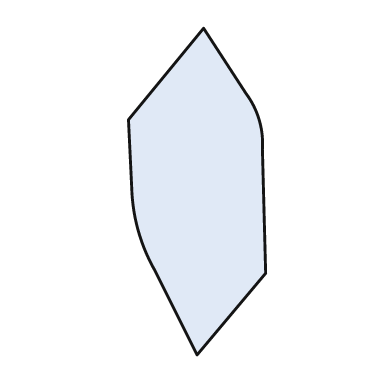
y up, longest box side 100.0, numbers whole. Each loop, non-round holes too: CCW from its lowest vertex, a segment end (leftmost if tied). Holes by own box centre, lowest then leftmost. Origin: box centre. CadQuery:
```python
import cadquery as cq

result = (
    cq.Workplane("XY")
    .moveTo(0.0, -50.0)
    .lineTo(21.0, -25.0)
    .lineTo(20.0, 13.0)
    .threePointArc((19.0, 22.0), (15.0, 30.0))
    .lineTo(2.0, 50.0)
    .lineTo(-21.0, 22.0)
    .lineTo(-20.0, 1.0)
    .threePointArc((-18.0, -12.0), (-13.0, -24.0))
    .close()
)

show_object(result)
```